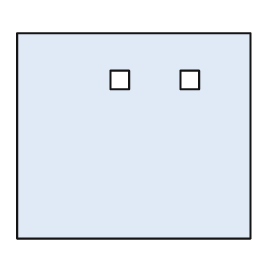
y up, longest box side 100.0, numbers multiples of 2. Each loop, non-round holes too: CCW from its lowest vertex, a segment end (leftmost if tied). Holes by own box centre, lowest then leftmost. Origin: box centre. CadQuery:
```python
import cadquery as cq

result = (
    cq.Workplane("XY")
    .moveTo(-50.0, -44.0)
    .lineTo(50.0, -44.0)
    .lineTo(50.0, 44.0)
    .lineTo(-50.0, 44.0)
    .close()
    .moveTo(-10.0, 20.0)
    .lineTo(-2.0, 20.0)
    .lineTo(-2.0, 28.0)
    .lineTo(-10.0, 28.0)
    .close()
    .moveTo(20.0, 20.0)
    .lineTo(28.0, 20.0)
    .lineTo(28.0, 28.0)
    .lineTo(20.0, 28.0)
    .close()
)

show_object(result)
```